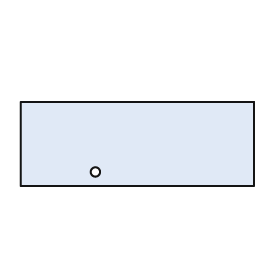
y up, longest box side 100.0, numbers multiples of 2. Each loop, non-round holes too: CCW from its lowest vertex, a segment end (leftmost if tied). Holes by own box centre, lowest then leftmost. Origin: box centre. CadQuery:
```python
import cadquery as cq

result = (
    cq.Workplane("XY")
    .moveTo(-50.0, -18.0)
    .lineTo(50.0, -18.0)
    .lineTo(50.0, 18.0)
    .lineTo(-50.0, 18.0)
    .close()
    .moveTo(-18.0, -12.0)
    .circle(2.0)
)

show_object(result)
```